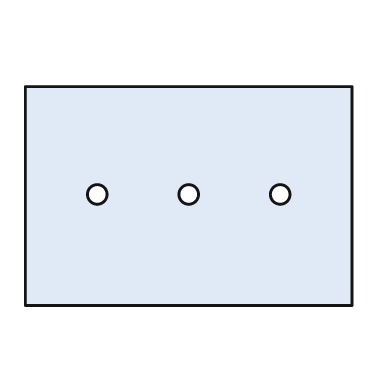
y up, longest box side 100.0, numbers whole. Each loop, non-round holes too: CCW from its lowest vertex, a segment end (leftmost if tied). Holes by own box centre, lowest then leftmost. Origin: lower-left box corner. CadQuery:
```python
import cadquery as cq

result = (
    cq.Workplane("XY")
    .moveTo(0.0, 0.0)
    .lineTo(100.0, 0.0)
    .lineTo(100.0, 67.0)
    .lineTo(0.0, 67.0)
    .close()
    .moveTo(22.0, 34.0)
    .circle(3.0)
    .moveTo(50.0, 34.0)
    .circle(3.0)
    .moveTo(78.0, 34.0)
    .circle(3.0)
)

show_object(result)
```